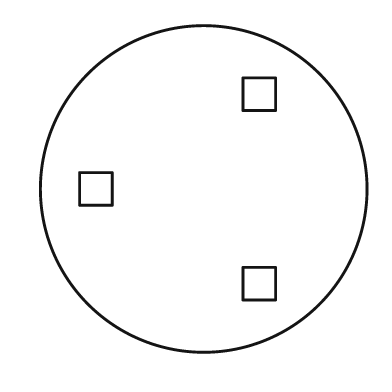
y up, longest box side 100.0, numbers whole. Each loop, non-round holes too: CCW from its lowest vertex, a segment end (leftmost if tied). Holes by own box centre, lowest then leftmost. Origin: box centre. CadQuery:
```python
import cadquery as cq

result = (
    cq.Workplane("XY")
    .moveTo(0.0, 0.0)
    .circle(50.0)
    .moveTo(12.0, -34.0)
    .lineTo(22.0, -34.0)
    .lineTo(22.0, -24.0)
    .lineTo(12.0, -24.0)
    .close()
    .moveTo(-38.0, -5.0)
    .lineTo(-28.0, -5.0)
    .lineTo(-28.0, 5.0)
    .lineTo(-38.0, 5.0)
    .close()
    .moveTo(12.0, 24.0)
    .lineTo(22.0, 24.0)
    .lineTo(22.0, 34.0)
    .lineTo(12.0, 34.0)
    .close()
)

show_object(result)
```